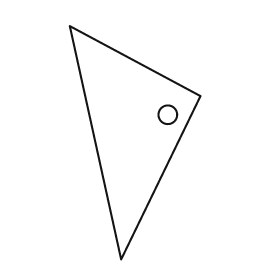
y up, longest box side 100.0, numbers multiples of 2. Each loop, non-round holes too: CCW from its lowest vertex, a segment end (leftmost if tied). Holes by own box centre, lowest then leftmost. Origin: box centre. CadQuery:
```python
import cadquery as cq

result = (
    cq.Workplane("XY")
    .moveTo(-6.0, -50.0)
    .lineTo(28.0, 20.0)
    .lineTo(-28.0, 50.0)
    .close()
    .moveTo(14.0, 12.0)
    .circle(4.0)
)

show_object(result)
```